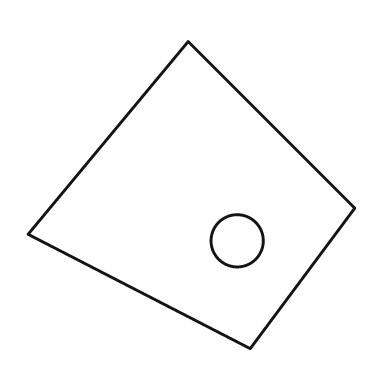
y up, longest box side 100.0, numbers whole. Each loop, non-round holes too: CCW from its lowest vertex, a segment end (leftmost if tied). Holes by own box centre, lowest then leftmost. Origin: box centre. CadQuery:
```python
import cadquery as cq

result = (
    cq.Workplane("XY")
    .moveTo(18.0, -47.0)
    .lineTo(50.0, -4.0)
    .lineTo(-1.0, 47.0)
    .lineTo(-50.0, -12.0)
    .close()
    .moveTo(14.0, -14.0)
    .circle(8.0)
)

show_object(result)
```